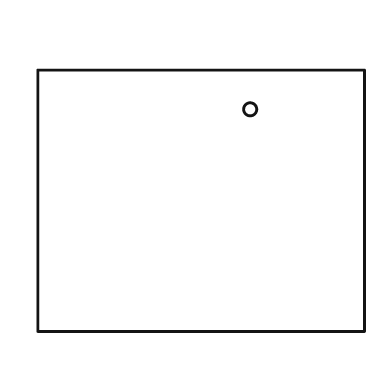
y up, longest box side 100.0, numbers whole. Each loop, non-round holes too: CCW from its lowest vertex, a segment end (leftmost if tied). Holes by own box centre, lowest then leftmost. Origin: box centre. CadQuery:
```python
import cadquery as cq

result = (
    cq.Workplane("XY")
    .moveTo(-50.0, -40.0)
    .lineTo(50.0, -40.0)
    .lineTo(50.0, 40.0)
    .lineTo(-50.0, 40.0)
    .close()
    .moveTo(15.0, 28.0)
    .circle(2.0)
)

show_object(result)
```